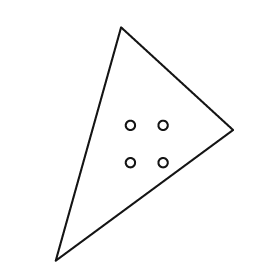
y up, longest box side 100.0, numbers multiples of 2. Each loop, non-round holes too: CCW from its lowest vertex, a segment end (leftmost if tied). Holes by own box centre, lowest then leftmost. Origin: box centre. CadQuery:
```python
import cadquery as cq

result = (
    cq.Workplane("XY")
    .moveTo(-38.0, -50.0)
    .lineTo(38.0, 6.0)
    .lineTo(-10.0, 50.0)
    .close()
    .moveTo(-6.0, -8.0)
    .circle(2.0)
    .moveTo(8.0, -8.0)
    .circle(2.0)
    .moveTo(-6.0, 8.0)
    .circle(2.0)
    .moveTo(8.0, 8.0)
    .circle(2.0)
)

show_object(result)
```